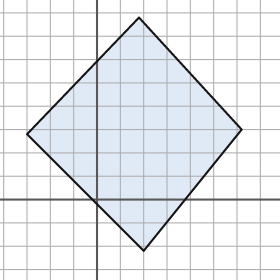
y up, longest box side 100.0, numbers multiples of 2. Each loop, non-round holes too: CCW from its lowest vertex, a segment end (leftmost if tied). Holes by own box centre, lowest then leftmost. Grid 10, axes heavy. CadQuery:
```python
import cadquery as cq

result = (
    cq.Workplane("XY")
    .moveTo(20.0, -22.0)
    .lineTo(62.0, 30.0)
    .lineTo(18.0, 78.0)
    .lineTo(-30.0, 28.0)
    .close()
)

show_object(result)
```